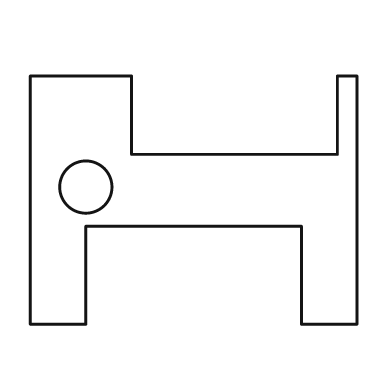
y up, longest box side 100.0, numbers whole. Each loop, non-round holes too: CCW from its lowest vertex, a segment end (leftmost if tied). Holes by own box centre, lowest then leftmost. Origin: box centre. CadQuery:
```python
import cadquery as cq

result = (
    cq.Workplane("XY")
    .moveTo(-50.0, -38.0)
    .lineTo(-33.0, -38.0)
    .lineTo(-33.0, -8.0)
    .lineTo(33.0, -8.0)
    .lineTo(33.0, -38.0)
    .lineTo(50.0, -38.0)
    .lineTo(50.0, 38.0)
    .lineTo(44.0, 38.0)
    .lineTo(44.0, 14.0)
    .lineTo(-19.0, 14.0)
    .lineTo(-19.0, 38.0)
    .lineTo(-50.0, 38.0)
    .close()
    .moveTo(-33.0, 4.0)
    .circle(8.0)
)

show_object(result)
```